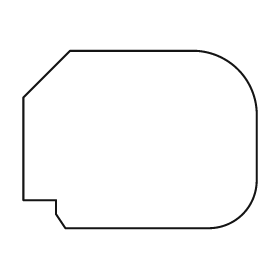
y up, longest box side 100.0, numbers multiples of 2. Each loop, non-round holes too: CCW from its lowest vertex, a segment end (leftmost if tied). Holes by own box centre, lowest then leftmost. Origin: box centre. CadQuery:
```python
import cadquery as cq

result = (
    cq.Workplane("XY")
    .moveTo(-32.0, -38.0)
    .lineTo(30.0, -38.0)
    .threePointArc((44.0, -32.0), (50.0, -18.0))
    .lineTo(50.0, 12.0)
    .threePointArc((42.0, 30.0), (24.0, 38.0))
    .lineTo(-30.0, 38.0)
    .lineTo(-50.0, 18.0)
    .lineTo(-50.0, -26.0)
    .lineTo(-36.0, -26.0)
    .lineTo(-36.0, -32.0)
    .close()
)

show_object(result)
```